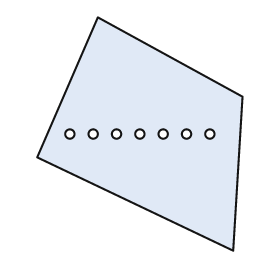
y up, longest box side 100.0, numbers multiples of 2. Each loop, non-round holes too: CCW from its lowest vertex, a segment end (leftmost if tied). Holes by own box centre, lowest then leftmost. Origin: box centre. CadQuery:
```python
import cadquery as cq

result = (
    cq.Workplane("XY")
    .moveTo(40.0, -50.0)
    .lineTo(44.0, 16.0)
    .lineTo(-18.0, 50.0)
    .lineTo(-44.0, -10.0)
    .close()
    .moveTo(-30.0, 0.0)
    .circle(2.0)
    .moveTo(-20.0, 0.0)
    .circle(2.0)
    .moveTo(-10.0, 0.0)
    .circle(2.0)
    .moveTo(0.0, 0.0)
    .circle(2.0)
    .moveTo(10.0, 0.0)
    .circle(2.0)
    .moveTo(20.0, 0.0)
    .circle(2.0)
    .moveTo(30.0, 0.0)
    .circle(2.0)
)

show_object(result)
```